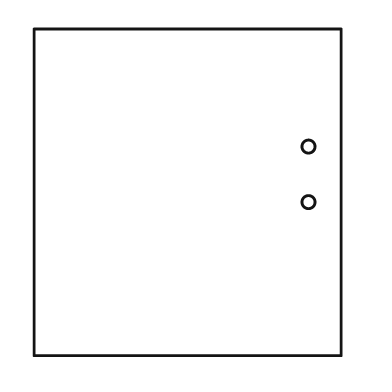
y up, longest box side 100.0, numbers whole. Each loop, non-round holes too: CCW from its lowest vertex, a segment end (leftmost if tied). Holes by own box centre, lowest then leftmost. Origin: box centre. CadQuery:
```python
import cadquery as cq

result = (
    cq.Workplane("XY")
    .moveTo(-47.0, -50.0)
    .lineTo(47.0, -50.0)
    .lineTo(47.0, 50.0)
    .lineTo(-47.0, 50.0)
    .close()
    .moveTo(37.0, -3.0)
    .circle(2.0)
    .moveTo(37.0, 14.0)
    .circle(2.0)
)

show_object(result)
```